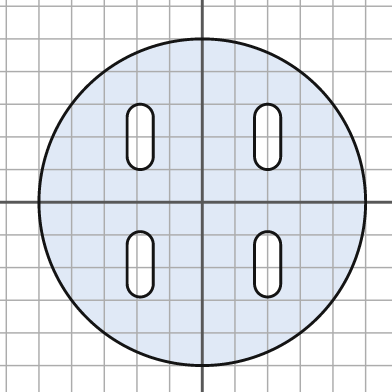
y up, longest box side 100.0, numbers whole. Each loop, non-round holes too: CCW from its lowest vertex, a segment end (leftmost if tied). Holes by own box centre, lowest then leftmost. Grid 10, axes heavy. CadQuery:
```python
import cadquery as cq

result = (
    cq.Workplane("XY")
    .moveTo(0.0, 0.0)
    .circle(50.0)
    .moveTo(-23.0, -25.0)
    .threePointArc((-19.0, -29.0), (-15.0, -25.0))
    .lineTo(-15.0, -13.0)
    .threePointArc((-19.0, -9.0), (-23.0, -13.0))
    .close()
    .moveTo(16.0, -25.0)
    .threePointArc((20.0, -29.0), (24.0, -25.0))
    .lineTo(24.0, -13.0)
    .threePointArc((20.0, -9.0), (16.0, -13.0))
    .close()
    .moveTo(-23.0, 14.0)
    .threePointArc((-19.0, 10.0), (-15.0, 14.0))
    .lineTo(-15.0, 26.0)
    .threePointArc((-19.0, 30.0), (-23.0, 26.0))
    .close()
    .moveTo(16.0, 14.0)
    .threePointArc((20.0, 10.0), (24.0, 14.0))
    .lineTo(24.0, 26.0)
    .threePointArc((20.0, 30.0), (16.0, 26.0))
    .close()
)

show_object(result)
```